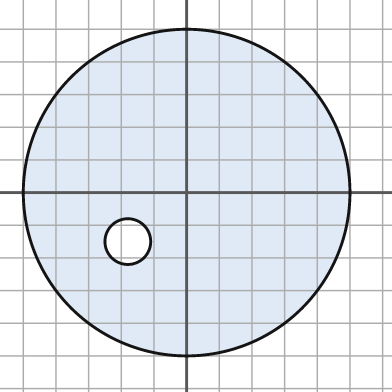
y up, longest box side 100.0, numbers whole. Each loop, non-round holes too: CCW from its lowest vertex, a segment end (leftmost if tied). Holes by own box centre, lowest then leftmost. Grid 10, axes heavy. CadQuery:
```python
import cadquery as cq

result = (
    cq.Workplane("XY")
    .moveTo(0.0, 0.0)
    .circle(50.0)
    .moveTo(-18.0, -15.0)
    .circle(7.0)
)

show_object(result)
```